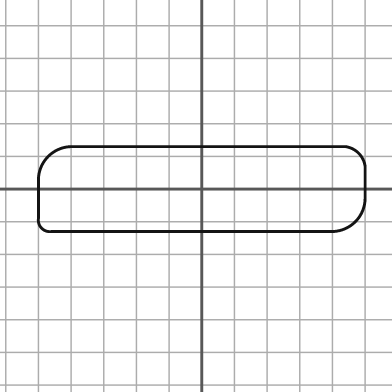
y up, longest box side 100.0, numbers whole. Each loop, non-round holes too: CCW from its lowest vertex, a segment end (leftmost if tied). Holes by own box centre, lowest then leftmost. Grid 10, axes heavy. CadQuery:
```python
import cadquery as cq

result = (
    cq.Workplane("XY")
    .moveTo(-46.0, -13.0)
    .lineTo(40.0, -13.0)
    .threePointArc((47.0, -10.0), (50.0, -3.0))
    .lineTo(50.0, 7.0)
    .threePointArc((48.0, 11.0), (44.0, 13.0))
    .lineTo(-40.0, 13.0)
    .threePointArc((-47.0, 10.0), (-50.0, 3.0))
    .lineTo(-50.0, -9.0)
    .threePointArc((-49.0, -12.0), (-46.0, -13.0))
    .close()
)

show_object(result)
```